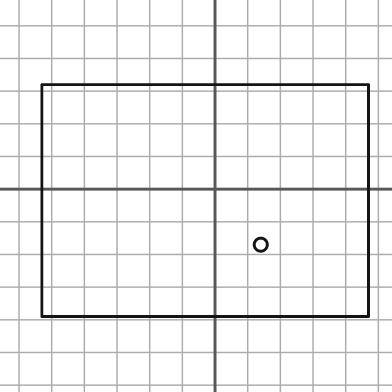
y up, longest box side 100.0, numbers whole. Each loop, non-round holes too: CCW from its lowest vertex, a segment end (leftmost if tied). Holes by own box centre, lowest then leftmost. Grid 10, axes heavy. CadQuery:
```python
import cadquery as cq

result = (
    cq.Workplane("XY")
    .moveTo(-53.0, -39.0)
    .lineTo(47.0, -39.0)
    .lineTo(47.0, 32.0)
    .lineTo(-53.0, 32.0)
    .close()
    .moveTo(14.0, -17.0)
    .circle(2.0)
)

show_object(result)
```